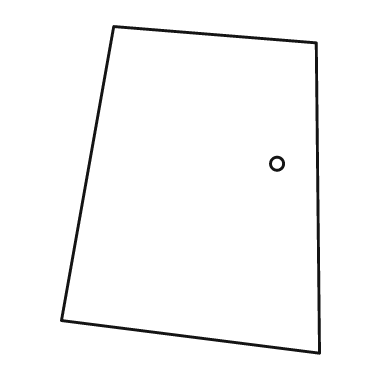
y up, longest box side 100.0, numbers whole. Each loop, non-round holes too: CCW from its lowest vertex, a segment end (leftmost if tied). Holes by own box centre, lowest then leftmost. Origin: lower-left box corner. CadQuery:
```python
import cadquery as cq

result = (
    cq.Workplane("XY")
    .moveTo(79.0, 0.0)
    .lineTo(78.0, 95.0)
    .lineTo(16.0, 100.0)
    .lineTo(0.0, 10.0)
    .close()
    .moveTo(66.0, 58.0)
    .circle(2.0)
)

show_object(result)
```